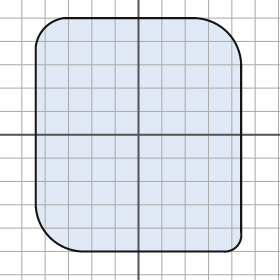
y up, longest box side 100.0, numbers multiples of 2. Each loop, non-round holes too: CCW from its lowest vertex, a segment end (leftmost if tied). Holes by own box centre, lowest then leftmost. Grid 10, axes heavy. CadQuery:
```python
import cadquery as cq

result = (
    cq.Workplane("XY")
    .moveTo(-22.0, -50.0)
    .lineTo(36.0, -50.0)
    .threePointArc((42.0, -48.0), (44.0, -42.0))
    .lineTo(44.0, 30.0)
    .threePointArc((38.0, 44.0), (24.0, 50.0))
    .lineTo(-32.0, 50.0)
    .threePointArc((-40.0, 46.0), (-44.0, 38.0))
    .lineTo(-44.0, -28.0)
    .threePointArc((-38.0, -44.0), (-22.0, -50.0))
    .close()
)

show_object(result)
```